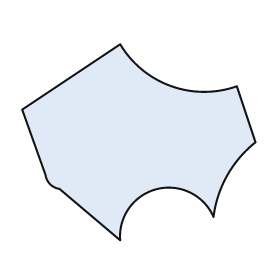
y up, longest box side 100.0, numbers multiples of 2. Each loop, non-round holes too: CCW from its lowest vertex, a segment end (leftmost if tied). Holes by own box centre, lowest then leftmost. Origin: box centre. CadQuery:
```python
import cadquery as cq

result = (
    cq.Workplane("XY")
    .moveTo(-8.0, -42.0)
    .threePointArc((8.0, -20.0), (32.0, -32.0))
    .threePointArc((38.0, -14.0), (50.0, 0.0))
    .lineTo(42.0, 24.0)
    .threePointArc((14.0, 24.0), (-8.0, 42.0))
    .lineTo(-50.0, 14.0)
    .lineTo(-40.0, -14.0)
    .threePointArc((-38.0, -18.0), (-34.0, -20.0))
    .close()
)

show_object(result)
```